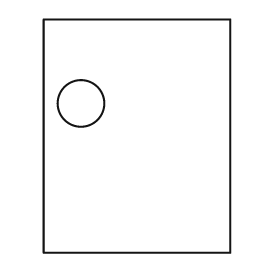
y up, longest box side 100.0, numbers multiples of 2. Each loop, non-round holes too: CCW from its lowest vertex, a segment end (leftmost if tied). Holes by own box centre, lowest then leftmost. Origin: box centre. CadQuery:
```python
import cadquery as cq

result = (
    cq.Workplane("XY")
    .moveTo(-40.0, -50.0)
    .lineTo(40.0, -50.0)
    .lineTo(40.0, 50.0)
    .lineTo(-40.0, 50.0)
    .close()
    .moveTo(-24.0, 14.0)
    .circle(10.0)
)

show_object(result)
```